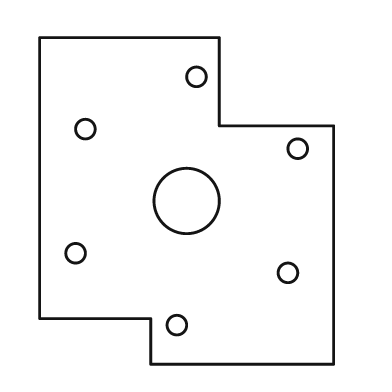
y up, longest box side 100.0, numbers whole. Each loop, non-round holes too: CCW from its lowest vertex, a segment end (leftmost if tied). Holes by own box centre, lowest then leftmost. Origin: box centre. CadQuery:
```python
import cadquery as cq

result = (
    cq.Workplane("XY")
    .moveTo(-11.0, -50.0)
    .lineTo(45.0, -50.0)
    .lineTo(45.0, 23.0)
    .lineTo(10.0, 23.0)
    .lineTo(10.0, 50.0)
    .lineTo(-45.0, 50.0)
    .lineTo(-45.0, -36.0)
    .lineTo(-11.0, -36.0)
    .close()
    .moveTo(-3.0, -38.0)
    .circle(3.0)
    .moveTo(31.0, -22.0)
    .circle(3.0)
    .moveTo(-34.0, -16.0)
    .circle(3.0)
    .moveTo(0.0, 0.0)
    .circle(10.0)
    .moveTo(34.0, 16.0)
    .circle(3.0)
    .moveTo(-31.0, 22.0)
    .circle(3.0)
    .moveTo(3.0, 38.0)
    .circle(3.0)
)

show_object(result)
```